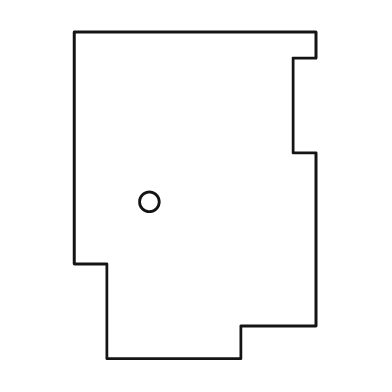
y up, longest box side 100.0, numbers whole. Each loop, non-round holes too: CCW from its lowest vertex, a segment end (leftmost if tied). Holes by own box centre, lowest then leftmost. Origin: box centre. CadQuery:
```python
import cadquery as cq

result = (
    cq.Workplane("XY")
    .moveTo(-27.0, -50.0)
    .lineTo(14.0, -50.0)
    .lineTo(14.0, -40.0)
    .lineTo(37.0, -40.0)
    .lineTo(37.0, 13.0)
    .lineTo(30.0, 13.0)
    .lineTo(30.0, 42.0)
    .lineTo(37.0, 42.0)
    .lineTo(37.0, 50.0)
    .lineTo(-37.0, 50.0)
    .lineTo(-37.0, -21.0)
    .lineTo(-27.0, -21.0)
    .close()
    .moveTo(-14.0, -2.0)
    .circle(3.0)
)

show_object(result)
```